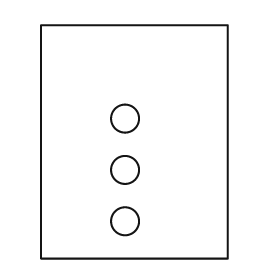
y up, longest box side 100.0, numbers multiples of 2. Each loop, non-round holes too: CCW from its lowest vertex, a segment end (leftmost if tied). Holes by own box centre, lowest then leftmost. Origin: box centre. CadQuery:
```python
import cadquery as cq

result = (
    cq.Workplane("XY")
    .moveTo(-40.0, -50.0)
    .lineTo(40.0, -50.0)
    .lineTo(40.0, 50.0)
    .lineTo(-40.0, 50.0)
    .close()
    .moveTo(-4.0, -34.0)
    .circle(6.0)
    .moveTo(-4.0, -12.0)
    .circle(6.0)
    .moveTo(-4.0, 10.0)
    .circle(6.0)
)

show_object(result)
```